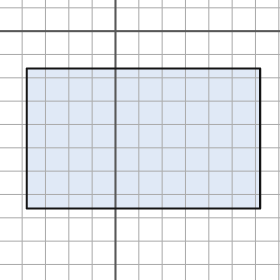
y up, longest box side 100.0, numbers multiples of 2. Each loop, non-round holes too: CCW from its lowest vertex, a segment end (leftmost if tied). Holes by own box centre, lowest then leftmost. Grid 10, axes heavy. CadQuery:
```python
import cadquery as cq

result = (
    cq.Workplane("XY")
    .moveTo(-38.0, -76.0)
    .lineTo(62.0, -76.0)
    .lineTo(62.0, -16.0)
    .lineTo(-38.0, -16.0)
    .close()
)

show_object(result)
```